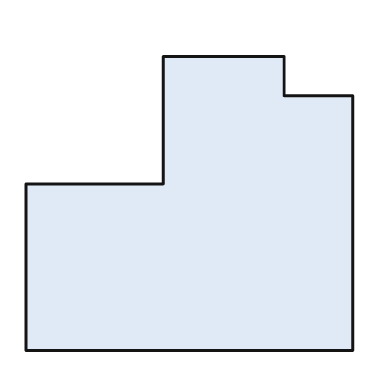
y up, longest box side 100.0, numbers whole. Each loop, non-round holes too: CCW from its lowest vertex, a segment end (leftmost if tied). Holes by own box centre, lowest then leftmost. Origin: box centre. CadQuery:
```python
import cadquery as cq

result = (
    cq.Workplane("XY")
    .moveTo(-50.0, -45.0)
    .lineTo(50.0, -45.0)
    .lineTo(50.0, 33.0)
    .lineTo(29.0, 33.0)
    .lineTo(29.0, 45.0)
    .lineTo(-8.0, 45.0)
    .lineTo(-8.0, 6.0)
    .lineTo(-50.0, 6.0)
    .close()
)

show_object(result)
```